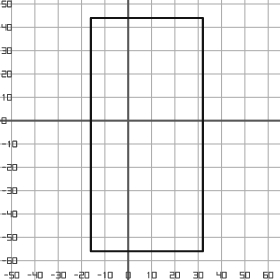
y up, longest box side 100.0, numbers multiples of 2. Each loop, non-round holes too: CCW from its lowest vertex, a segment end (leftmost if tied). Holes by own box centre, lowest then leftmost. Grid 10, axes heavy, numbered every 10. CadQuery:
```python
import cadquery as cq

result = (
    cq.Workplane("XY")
    .moveTo(-16.0, -56.0)
    .lineTo(32.0, -56.0)
    .lineTo(32.0, 44.0)
    .lineTo(-16.0, 44.0)
    .close()
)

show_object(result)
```